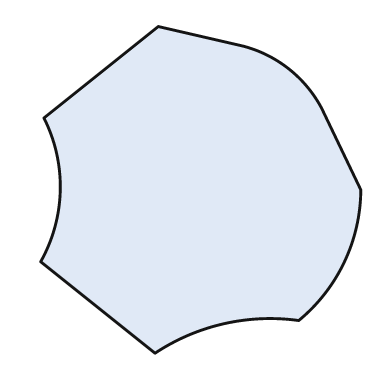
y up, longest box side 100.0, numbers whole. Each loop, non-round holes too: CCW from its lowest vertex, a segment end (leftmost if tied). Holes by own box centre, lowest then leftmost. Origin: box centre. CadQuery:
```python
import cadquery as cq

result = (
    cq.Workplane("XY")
    .moveTo(-14.0, -50.0)
    .threePointArc((7.0, -41.0), (30.0, -40.0))
    .threePointArc((44.0, -22.0), (49.0, 0.0))
    .lineTo(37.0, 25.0)
    .threePointArc((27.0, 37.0), (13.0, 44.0))
    .lineTo(-13.0, 50.0)
    .lineTo(-48.0, 22.0)
    .threePointArc((-43.0, 0.0), (-49.0, -22.0))
    .close()
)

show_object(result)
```